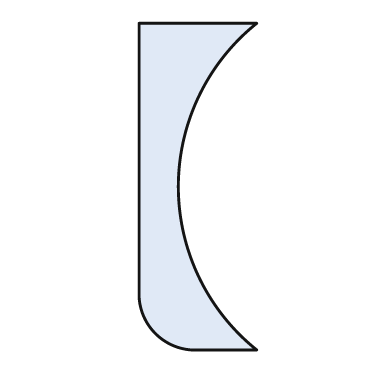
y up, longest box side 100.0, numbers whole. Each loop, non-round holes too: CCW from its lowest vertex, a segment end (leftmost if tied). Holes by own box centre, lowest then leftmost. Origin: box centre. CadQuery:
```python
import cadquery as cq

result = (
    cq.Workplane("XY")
    .moveTo(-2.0, -50.0)
    .lineTo(18.0, -50.0)
    .threePointArc((-6.0, 0.0), (18.0, 50.0))
    .lineTo(-18.0, 50.0)
    .lineTo(-18.0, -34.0)
    .threePointArc((-13.0, -45.0), (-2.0, -50.0))
    .close()
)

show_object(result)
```